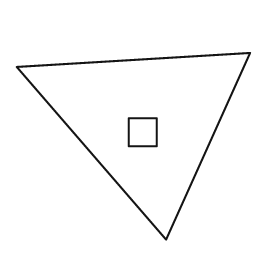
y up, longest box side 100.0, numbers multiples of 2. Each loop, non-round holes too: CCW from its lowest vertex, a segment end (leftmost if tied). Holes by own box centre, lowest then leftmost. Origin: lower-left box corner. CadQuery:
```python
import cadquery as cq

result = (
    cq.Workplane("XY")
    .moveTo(64.0, 0.0)
    .lineTo(100.0, 80.0)
    .lineTo(0.0, 74.0)
    .close()
    .moveTo(48.0, 40.0)
    .lineTo(60.0, 40.0)
    .lineTo(60.0, 52.0)
    .lineTo(48.0, 52.0)
    .close()
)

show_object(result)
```